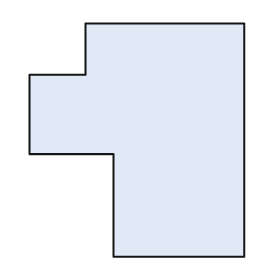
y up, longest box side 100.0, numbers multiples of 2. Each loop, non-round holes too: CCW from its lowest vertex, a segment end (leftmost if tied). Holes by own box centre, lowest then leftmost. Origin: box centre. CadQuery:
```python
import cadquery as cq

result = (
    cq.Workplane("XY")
    .moveTo(-10.0, -50.0)
    .lineTo(46.0, -50.0)
    .lineTo(46.0, 50.0)
    .lineTo(-22.0, 50.0)
    .lineTo(-22.0, 28.0)
    .lineTo(-46.0, 28.0)
    .lineTo(-46.0, -6.0)
    .lineTo(-10.0, -6.0)
    .close()
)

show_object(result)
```